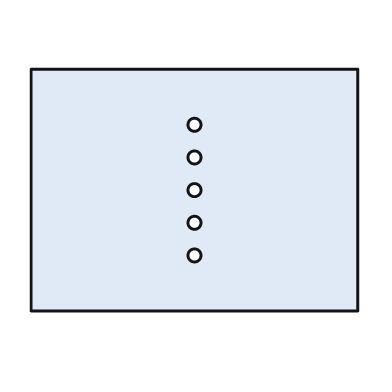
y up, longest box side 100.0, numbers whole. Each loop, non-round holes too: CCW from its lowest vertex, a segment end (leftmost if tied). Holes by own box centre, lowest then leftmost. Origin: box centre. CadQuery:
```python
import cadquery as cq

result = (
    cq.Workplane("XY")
    .moveTo(-50.0, -37.0)
    .lineTo(50.0, -37.0)
    .lineTo(50.0, 37.0)
    .lineTo(-50.0, 37.0)
    .close()
    .moveTo(0.0, -20.0)
    .circle(2.0)
    .moveTo(0.0, -10.0)
    .circle(2.0)
    .moveTo(0.0, 0.0)
    .circle(2.0)
    .moveTo(0.0, 10.0)
    .circle(2.0)
    .moveTo(0.0, 20.0)
    .circle(2.0)
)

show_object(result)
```